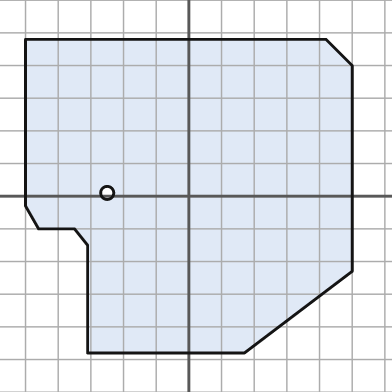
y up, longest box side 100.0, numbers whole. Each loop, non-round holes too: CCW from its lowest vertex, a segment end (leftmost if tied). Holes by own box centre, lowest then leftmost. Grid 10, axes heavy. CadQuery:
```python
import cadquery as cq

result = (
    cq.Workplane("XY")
    .moveTo(-31.0, -48.0)
    .lineTo(17.0, -48.0)
    .lineTo(50.0, -23.0)
    .lineTo(50.0, 40.0)
    .lineTo(42.0, 48.0)
    .lineTo(-50.0, 48.0)
    .lineTo(-50.0, -3.0)
    .lineTo(-46.0, -10.0)
    .lineTo(-35.0, -10.0)
    .lineTo(-31.0, -15.0)
    .close()
    .moveTo(-25.0, 1.0)
    .circle(2.0)
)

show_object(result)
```